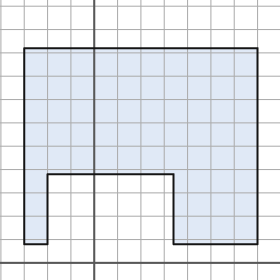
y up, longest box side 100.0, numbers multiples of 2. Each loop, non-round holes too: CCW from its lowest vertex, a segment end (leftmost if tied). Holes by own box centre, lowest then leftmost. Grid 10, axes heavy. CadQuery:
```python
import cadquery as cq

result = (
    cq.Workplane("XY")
    .moveTo(-30.0, 8.0)
    .lineTo(-20.0, 8.0)
    .lineTo(-20.0, 38.0)
    .lineTo(34.0, 38.0)
    .lineTo(34.0, 8.0)
    .lineTo(70.0, 8.0)
    .lineTo(70.0, 92.0)
    .lineTo(-30.0, 92.0)
    .close()
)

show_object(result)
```